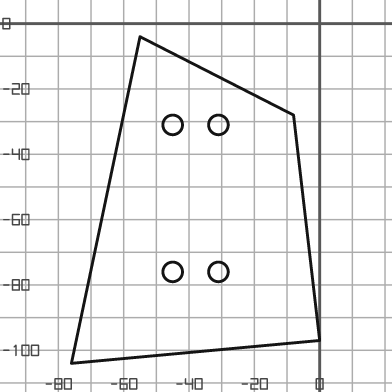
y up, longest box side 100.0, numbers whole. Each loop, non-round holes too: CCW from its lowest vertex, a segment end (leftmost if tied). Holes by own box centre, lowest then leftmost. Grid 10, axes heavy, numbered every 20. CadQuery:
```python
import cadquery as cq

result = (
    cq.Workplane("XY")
    .moveTo(-76.0, -104.0)
    .lineTo(0.0, -97.0)
    .lineTo(-8.0, -28.0)
    .lineTo(-55.0, -4.0)
    .close()
    .moveTo(-45.0, -76.0)
    .circle(3.0)
    .moveTo(-31.0, -76.0)
    .circle(3.0)
    .moveTo(-45.0, -31.0)
    .circle(3.0)
    .moveTo(-31.0, -31.0)
    .circle(3.0)
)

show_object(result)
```